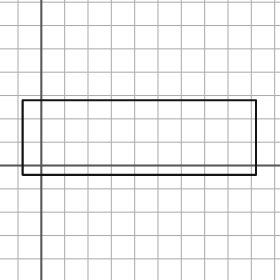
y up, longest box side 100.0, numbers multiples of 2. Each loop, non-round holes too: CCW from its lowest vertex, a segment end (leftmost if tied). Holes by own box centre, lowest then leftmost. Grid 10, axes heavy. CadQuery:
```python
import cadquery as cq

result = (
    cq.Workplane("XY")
    .moveTo(-8.0, -4.0)
    .lineTo(92.0, -4.0)
    .lineTo(92.0, 28.0)
    .lineTo(-8.0, 28.0)
    .close()
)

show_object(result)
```